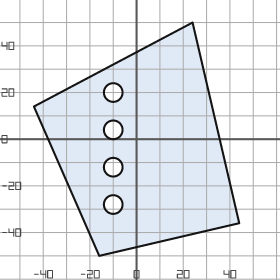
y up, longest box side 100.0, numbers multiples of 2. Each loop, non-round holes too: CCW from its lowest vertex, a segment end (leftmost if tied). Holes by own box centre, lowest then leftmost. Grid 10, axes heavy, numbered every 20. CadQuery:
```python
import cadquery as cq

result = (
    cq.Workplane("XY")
    .moveTo(-16.0, -50.0)
    .lineTo(44.0, -36.0)
    .lineTo(24.0, 50.0)
    .lineTo(-44.0, 14.0)
    .close()
    .moveTo(-10.0, -28.0)
    .circle(4.0)
    .moveTo(-10.0, -12.0)
    .circle(4.0)
    .moveTo(-10.0, 4.0)
    .circle(4.0)
    .moveTo(-10.0, 20.0)
    .circle(4.0)
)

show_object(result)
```